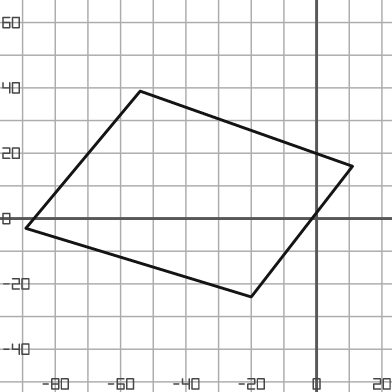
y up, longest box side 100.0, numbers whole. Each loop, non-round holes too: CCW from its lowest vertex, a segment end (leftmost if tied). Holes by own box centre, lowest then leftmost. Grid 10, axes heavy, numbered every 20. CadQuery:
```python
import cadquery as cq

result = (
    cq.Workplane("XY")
    .moveTo(-20.0, -24.0)
    .lineTo(11.0, 16.0)
    .lineTo(-54.0, 39.0)
    .lineTo(-89.0, -3.0)
    .close()
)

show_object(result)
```